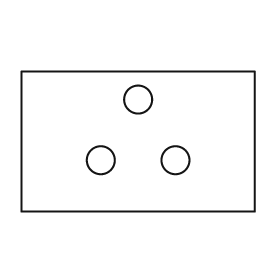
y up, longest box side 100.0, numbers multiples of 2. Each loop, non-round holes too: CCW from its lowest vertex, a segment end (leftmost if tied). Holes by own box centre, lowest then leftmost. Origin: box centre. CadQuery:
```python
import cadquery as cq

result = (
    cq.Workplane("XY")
    .moveTo(-50.0, -30.0)
    .lineTo(50.0, -30.0)
    .lineTo(50.0, 30.0)
    .lineTo(-50.0, 30.0)
    .close()
    .moveTo(-16.0, -8.0)
    .circle(6.0)
    .moveTo(16.0, -8.0)
    .circle(6.0)
    .moveTo(0.0, 18.0)
    .circle(6.0)
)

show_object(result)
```